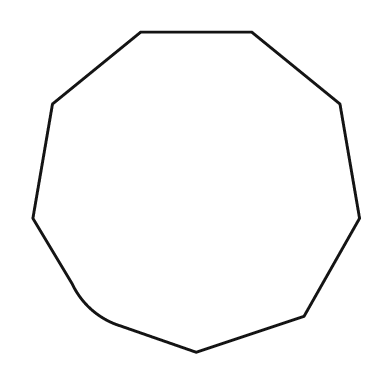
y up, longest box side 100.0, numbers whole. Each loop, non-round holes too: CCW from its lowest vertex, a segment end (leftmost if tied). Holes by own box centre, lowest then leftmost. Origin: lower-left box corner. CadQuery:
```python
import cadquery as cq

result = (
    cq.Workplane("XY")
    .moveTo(50.0, 0.0)
    .lineTo(83.0, 11.0)
    .lineTo(100.0, 41.0)
    .lineTo(94.0, 76.0)
    .lineTo(67.0, 98.0)
    .lineTo(33.0, 98.0)
    .lineTo(6.0, 76.0)
    .lineTo(0.0, 41.0)
    .lineTo(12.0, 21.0)
    .threePointArc((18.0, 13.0), (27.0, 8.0))
    .close()
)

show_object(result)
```